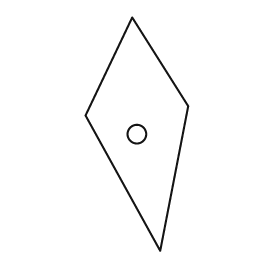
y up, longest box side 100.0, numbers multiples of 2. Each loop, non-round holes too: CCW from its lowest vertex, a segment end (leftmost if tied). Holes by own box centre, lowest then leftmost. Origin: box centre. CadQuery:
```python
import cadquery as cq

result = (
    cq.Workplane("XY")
    .moveTo(10.0, -50.0)
    .lineTo(22.0, 12.0)
    .lineTo(-2.0, 50.0)
    .lineTo(-22.0, 8.0)
    .close()
    .moveTo(0.0, 0.0)
    .circle(4.0)
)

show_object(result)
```